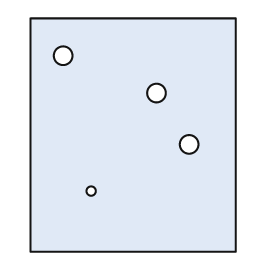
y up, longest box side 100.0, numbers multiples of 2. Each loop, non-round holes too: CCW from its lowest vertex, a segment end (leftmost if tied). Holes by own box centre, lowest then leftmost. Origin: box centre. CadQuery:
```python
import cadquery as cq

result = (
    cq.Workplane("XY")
    .moveTo(-44.0, -50.0)
    .lineTo(44.0, -50.0)
    .lineTo(44.0, 50.0)
    .lineTo(-44.0, 50.0)
    .close()
    .moveTo(-18.0, -24.0)
    .circle(2.0)
    .moveTo(24.0, -4.0)
    .circle(4.0)
    .moveTo(10.0, 18.0)
    .circle(4.0)
    .moveTo(-30.0, 34.0)
    .circle(4.0)
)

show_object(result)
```